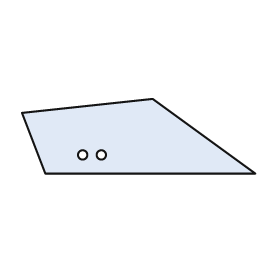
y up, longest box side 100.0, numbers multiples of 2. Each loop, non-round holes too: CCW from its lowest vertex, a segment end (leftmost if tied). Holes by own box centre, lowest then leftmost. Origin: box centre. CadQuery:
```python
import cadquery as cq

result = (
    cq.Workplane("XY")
    .moveTo(-40.0, -16.0)
    .lineTo(50.0, -16.0)
    .lineTo(6.0, 16.0)
    .lineTo(-50.0, 10.0)
    .close()
    .moveTo(-24.0, -8.0)
    .circle(2.0)
    .moveTo(-16.0, -8.0)
    .circle(2.0)
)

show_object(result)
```